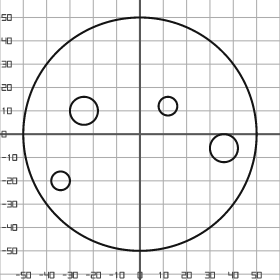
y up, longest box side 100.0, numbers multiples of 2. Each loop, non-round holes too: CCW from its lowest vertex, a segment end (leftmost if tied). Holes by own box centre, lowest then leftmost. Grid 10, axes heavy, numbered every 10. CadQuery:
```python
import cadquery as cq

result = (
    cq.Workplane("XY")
    .moveTo(0.0, 0.0)
    .circle(50.0)
    .moveTo(-34.0, -20.0)
    .circle(4.0)
    .moveTo(36.0, -6.0)
    .circle(6.0)
    .moveTo(-24.0, 10.0)
    .circle(6.0)
    .moveTo(12.0, 12.0)
    .circle(4.0)
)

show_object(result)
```